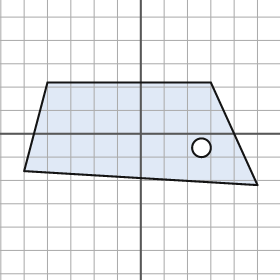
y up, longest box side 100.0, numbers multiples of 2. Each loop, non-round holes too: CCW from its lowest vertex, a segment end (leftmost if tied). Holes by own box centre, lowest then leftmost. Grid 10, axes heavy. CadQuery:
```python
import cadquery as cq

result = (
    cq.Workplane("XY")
    .moveTo(50.0, -22.0)
    .lineTo(30.0, 22.0)
    .lineTo(-40.0, 22.0)
    .lineTo(-50.0, -16.0)
    .close()
    .moveTo(26.0, -6.0)
    .circle(4.0)
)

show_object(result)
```